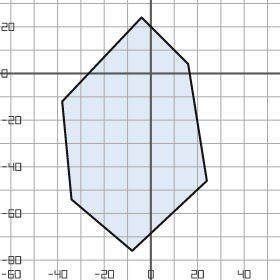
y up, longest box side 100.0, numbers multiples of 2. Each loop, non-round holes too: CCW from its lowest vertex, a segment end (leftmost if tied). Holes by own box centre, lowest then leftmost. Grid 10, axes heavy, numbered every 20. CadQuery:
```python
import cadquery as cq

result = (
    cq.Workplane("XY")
    .moveTo(-8.0, -76.0)
    .lineTo(24.0, -46.0)
    .lineTo(16.0, 4.0)
    .lineTo(-4.0, 24.0)
    .lineTo(-38.0, -12.0)
    .lineTo(-34.0, -54.0)
    .close()
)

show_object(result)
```